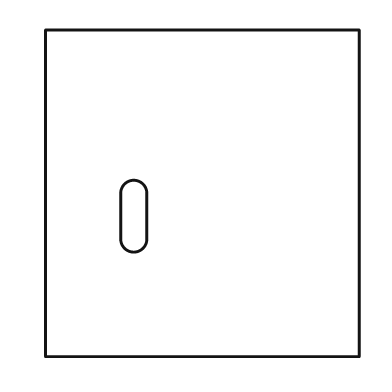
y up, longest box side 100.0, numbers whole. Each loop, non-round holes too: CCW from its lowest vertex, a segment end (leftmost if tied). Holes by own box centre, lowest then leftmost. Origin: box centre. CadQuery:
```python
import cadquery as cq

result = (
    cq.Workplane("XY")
    .moveTo(-48.0, -50.0)
    .lineTo(48.0, -50.0)
    .lineTo(48.0, 50.0)
    .lineTo(-48.0, 50.0)
    .close()
    .moveTo(-25.0, -14.0)
    .threePointArc((-21.0, -18.0), (-17.0, -14.0))
    .lineTo(-17.0, 0.0)
    .threePointArc((-21.0, 4.0), (-25.0, 0.0))
    .close()
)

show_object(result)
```